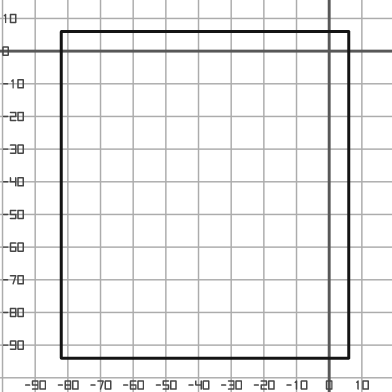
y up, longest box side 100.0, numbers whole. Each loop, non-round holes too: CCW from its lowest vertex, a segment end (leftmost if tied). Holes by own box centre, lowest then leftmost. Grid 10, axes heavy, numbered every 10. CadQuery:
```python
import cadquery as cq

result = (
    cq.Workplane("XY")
    .moveTo(-82.0, -94.0)
    .lineTo(6.0, -94.0)
    .lineTo(6.0, 6.0)
    .lineTo(-82.0, 6.0)
    .close()
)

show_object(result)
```